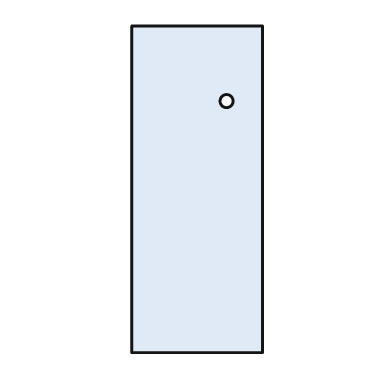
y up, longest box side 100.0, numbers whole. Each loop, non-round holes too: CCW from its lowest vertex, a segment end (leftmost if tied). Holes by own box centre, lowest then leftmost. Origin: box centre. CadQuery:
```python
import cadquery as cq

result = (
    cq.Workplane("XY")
    .moveTo(-20.0, -50.0)
    .lineTo(20.0, -50.0)
    .lineTo(20.0, 50.0)
    .lineTo(-20.0, 50.0)
    .close()
    .moveTo(9.0, 27.0)
    .circle(2.0)
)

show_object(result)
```